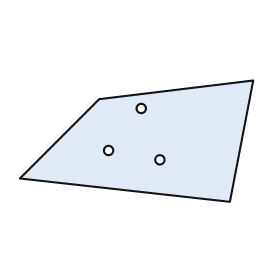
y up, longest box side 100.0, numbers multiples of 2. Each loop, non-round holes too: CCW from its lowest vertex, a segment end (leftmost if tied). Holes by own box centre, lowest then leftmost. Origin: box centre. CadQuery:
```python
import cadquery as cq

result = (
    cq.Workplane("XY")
    .moveTo(40.0, -26.0)
    .lineTo(50.0, 26.0)
    .lineTo(-16.0, 18.0)
    .lineTo(-50.0, -16.0)
    .close()
    .moveTo(10.0, -8.0)
    .circle(2.0)
    .moveTo(-12.0, -4.0)
    .circle(2.0)
    .moveTo(2.0, 14.0)
    .circle(2.0)
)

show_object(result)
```